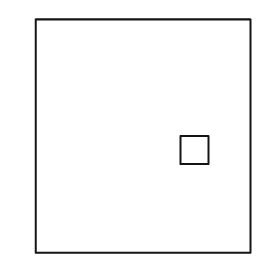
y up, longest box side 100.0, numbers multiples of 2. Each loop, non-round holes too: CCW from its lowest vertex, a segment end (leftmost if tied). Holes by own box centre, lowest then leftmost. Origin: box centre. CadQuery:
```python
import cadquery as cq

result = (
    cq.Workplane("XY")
    .moveTo(-46.0, -50.0)
    .lineTo(46.0, -50.0)
    .lineTo(46.0, 50.0)
    .lineTo(-46.0, 50.0)
    .close()
    .moveTo(16.0, -12.0)
    .lineTo(28.0, -12.0)
    .lineTo(28.0, 0.0)
    .lineTo(16.0, 0.0)
    .close()
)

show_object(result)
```